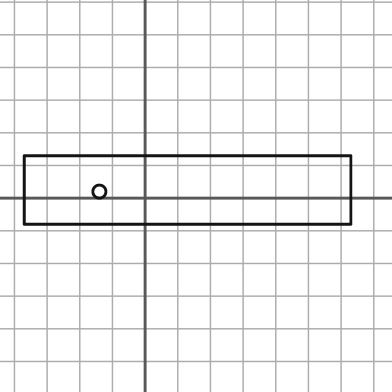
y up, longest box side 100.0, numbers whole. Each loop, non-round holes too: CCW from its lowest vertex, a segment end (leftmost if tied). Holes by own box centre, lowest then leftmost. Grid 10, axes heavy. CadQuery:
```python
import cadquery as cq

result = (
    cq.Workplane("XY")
    .moveTo(-37.0, -8.0)
    .lineTo(63.0, -8.0)
    .lineTo(63.0, 13.0)
    .lineTo(-37.0, 13.0)
    .close()
    .moveTo(-14.0, 2.0)
    .circle(2.0)
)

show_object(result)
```